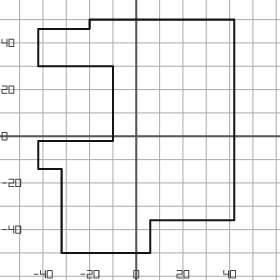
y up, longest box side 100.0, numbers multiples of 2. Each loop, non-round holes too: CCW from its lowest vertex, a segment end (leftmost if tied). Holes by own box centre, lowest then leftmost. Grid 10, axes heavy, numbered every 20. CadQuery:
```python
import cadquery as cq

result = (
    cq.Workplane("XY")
    .moveTo(-32.0, -50.0)
    .lineTo(6.0, -50.0)
    .lineTo(6.0, -36.0)
    .lineTo(42.0, -36.0)
    .lineTo(42.0, 50.0)
    .lineTo(-20.0, 50.0)
    .lineTo(-20.0, 46.0)
    .lineTo(-42.0, 46.0)
    .lineTo(-42.0, 30.0)
    .lineTo(-10.0, 30.0)
    .lineTo(-10.0, -2.0)
    .lineTo(-42.0, -2.0)
    .lineTo(-42.0, -14.0)
    .lineTo(-32.0, -14.0)
    .close()
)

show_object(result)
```